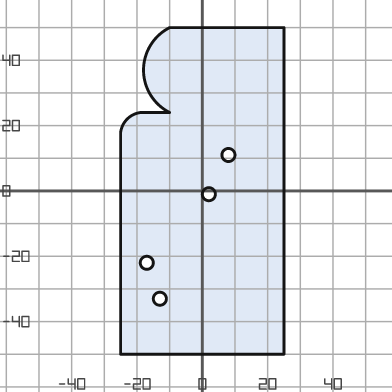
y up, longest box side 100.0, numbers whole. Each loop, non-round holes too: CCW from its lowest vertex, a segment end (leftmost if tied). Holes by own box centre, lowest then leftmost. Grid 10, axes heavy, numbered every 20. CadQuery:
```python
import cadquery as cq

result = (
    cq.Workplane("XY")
    .moveTo(-25.0, -50.0)
    .lineTo(25.0, -50.0)
    .lineTo(25.0, 50.0)
    .lineTo(-10.0, 50.0)
    .threePointArc((-18.0, 37.0), (-10.0, 24.0))
    .lineTo(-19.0, 24.0)
    .threePointArc((-23.0, 22.0), (-25.0, 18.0))
    .close()
    .moveTo(-13.0, -33.0)
    .circle(2.0)
    .moveTo(-17.0, -22.0)
    .circle(2.0)
    .moveTo(2.0, -1.0)
    .circle(2.0)
    .moveTo(8.0, 11.0)
    .circle(2.0)
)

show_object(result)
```